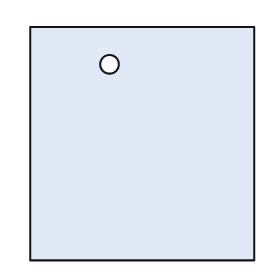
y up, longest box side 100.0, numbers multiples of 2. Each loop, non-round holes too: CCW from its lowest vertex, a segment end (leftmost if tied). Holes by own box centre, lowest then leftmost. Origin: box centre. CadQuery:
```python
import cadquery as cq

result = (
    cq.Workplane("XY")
    .moveTo(-48.0, -50.0)
    .lineTo(48.0, -50.0)
    .lineTo(48.0, 50.0)
    .lineTo(-48.0, 50.0)
    .close()
    .moveTo(-14.0, 34.0)
    .circle(4.0)
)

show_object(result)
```